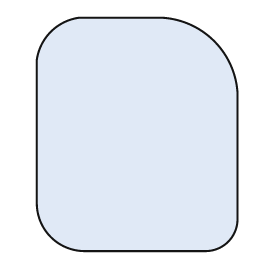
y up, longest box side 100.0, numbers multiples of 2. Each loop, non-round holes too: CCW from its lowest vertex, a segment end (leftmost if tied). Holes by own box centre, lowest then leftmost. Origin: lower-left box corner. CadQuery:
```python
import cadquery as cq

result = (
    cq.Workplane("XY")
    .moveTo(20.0, 0.0)
    .lineTo(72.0, 0.0)
    .threePointArc((82.0, 4.0), (86.0, 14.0))
    .lineTo(86.0, 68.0)
    .threePointArc((76.0, 90.0), (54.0, 100.0))
    .lineTo(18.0, 100.0)
    .threePointArc((6.0, 94.0), (0.0, 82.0))
    .lineTo(0.0, 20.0)
    .threePointArc((6.0, 6.0), (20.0, 0.0))
    .close()
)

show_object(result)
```